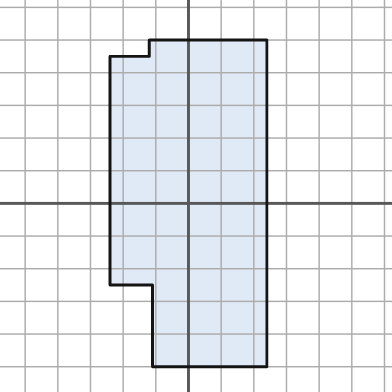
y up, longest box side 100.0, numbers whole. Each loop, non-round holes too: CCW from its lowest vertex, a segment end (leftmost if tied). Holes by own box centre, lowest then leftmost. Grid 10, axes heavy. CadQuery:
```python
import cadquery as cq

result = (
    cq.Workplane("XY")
    .moveTo(-11.0, -50.0)
    .lineTo(24.0, -50.0)
    .lineTo(24.0, 50.0)
    .lineTo(-12.0, 50.0)
    .lineTo(-12.0, 45.0)
    .lineTo(-24.0, 45.0)
    .lineTo(-24.0, -25.0)
    .lineTo(-11.0, -25.0)
    .close()
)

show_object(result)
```